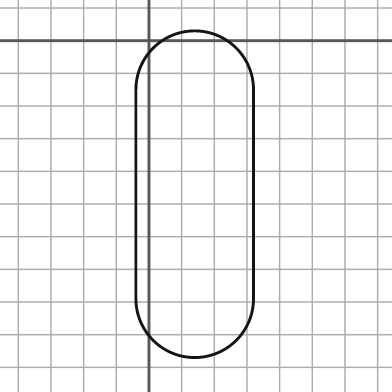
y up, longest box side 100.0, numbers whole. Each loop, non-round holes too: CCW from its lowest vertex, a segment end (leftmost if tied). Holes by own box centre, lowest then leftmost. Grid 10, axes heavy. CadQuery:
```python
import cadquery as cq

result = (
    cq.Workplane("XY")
    .moveTo(-4.0, -79.0)
    .threePointArc((14.0, -97.0), (32.0, -79.0))
    .lineTo(32.0, -15.0)
    .threePointArc((14.0, 3.0), (-4.0, -15.0))
    .close()
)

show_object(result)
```